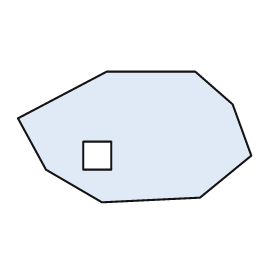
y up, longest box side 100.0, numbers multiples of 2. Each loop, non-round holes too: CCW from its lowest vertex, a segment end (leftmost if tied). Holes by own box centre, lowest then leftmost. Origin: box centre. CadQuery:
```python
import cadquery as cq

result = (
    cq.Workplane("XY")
    .moveTo(-14.0, -28.0)
    .lineTo(28.0, -26.0)
    .lineTo(50.0, -8.0)
    .lineTo(42.0, 14.0)
    .lineTo(26.0, 28.0)
    .lineTo(-12.0, 28.0)
    .lineTo(-50.0, 8.0)
    .lineTo(-38.0, -14.0)
    .close()
    .moveTo(-22.0, -14.0)
    .lineTo(-10.0, -14.0)
    .lineTo(-10.0, -2.0)
    .lineTo(-22.0, -2.0)
    .close()
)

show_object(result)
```